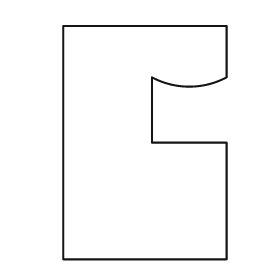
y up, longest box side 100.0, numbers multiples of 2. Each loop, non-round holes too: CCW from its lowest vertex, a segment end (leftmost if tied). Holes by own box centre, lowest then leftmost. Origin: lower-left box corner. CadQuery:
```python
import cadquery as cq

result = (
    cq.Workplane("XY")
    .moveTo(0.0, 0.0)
    .lineTo(70.0, 0.0)
    .lineTo(70.0, 50.0)
    .lineTo(38.0, 50.0)
    .lineTo(38.0, 78.0)
    .threePointArc((54.0, 74.0), (70.0, 78.0))
    .lineTo(70.0, 100.0)
    .lineTo(0.0, 100.0)
    .close()
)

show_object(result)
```